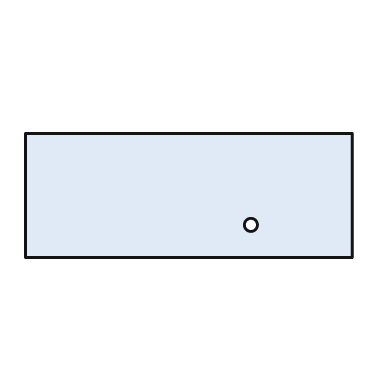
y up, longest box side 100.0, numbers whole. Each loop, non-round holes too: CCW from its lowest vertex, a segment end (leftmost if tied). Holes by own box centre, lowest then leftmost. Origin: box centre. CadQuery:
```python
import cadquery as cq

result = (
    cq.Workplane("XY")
    .moveTo(-50.0, -19.0)
    .lineTo(50.0, -19.0)
    .lineTo(50.0, 19.0)
    .lineTo(-50.0, 19.0)
    .close()
    .moveTo(19.0, -9.0)
    .circle(2.0)
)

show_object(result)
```